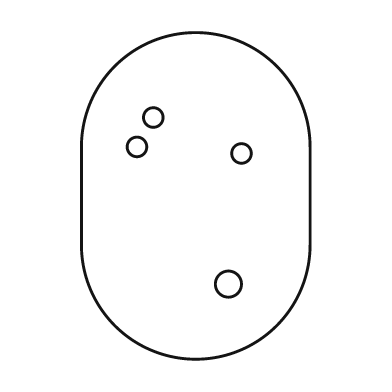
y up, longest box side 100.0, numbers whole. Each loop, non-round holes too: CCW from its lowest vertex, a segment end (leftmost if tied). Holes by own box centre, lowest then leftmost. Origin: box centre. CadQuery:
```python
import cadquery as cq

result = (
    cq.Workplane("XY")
    .moveTo(-35.0, -15.0)
    .threePointArc((0.0, -50.0), (35.0, -15.0))
    .lineTo(35.0, 15.0)
    .threePointArc((0.0, 50.0), (-35.0, 15.0))
    .close()
    .moveTo(10.0, -27.0)
    .circle(4.0)
    .moveTo(14.0, 13.0)
    .circle(3.0)
    .moveTo(-18.0, 15.0)
    .circle(3.0)
    .moveTo(-13.0, 24.0)
    .circle(3.0)
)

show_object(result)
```